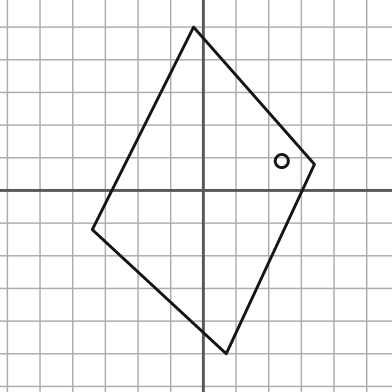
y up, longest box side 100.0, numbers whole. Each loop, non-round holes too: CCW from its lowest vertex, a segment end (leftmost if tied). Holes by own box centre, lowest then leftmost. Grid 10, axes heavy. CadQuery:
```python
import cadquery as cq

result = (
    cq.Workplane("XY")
    .moveTo(7.0, -50.0)
    .lineTo(34.0, 8.0)
    .lineTo(-3.0, 50.0)
    .lineTo(-34.0, -12.0)
    .close()
    .moveTo(24.0, 9.0)
    .circle(2.0)
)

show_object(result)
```